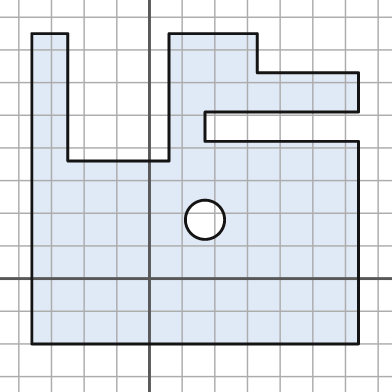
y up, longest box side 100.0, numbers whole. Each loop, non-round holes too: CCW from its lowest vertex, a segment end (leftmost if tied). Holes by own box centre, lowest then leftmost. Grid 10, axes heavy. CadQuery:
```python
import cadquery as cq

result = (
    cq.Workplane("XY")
    .moveTo(-36.0, -20.0)
    .lineTo(64.0, -20.0)
    .lineTo(64.0, 42.0)
    .lineTo(17.0, 42.0)
    .lineTo(17.0, 51.0)
    .lineTo(64.0, 51.0)
    .lineTo(64.0, 63.0)
    .lineTo(33.0, 63.0)
    .lineTo(33.0, 75.0)
    .lineTo(6.0, 75.0)
    .lineTo(6.0, 36.0)
    .lineTo(-25.0, 36.0)
    .lineTo(-25.0, 75.0)
    .lineTo(-36.0, 75.0)
    .close()
    .moveTo(17.0, 18.0)
    .circle(6.0)
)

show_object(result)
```